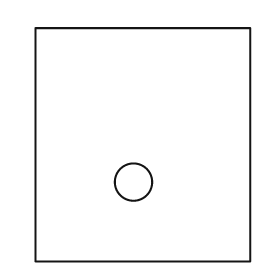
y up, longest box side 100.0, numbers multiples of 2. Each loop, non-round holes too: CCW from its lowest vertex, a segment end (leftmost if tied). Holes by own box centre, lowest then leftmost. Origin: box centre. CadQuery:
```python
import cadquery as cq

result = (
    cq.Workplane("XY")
    .moveTo(-46.0, -50.0)
    .lineTo(46.0, -50.0)
    .lineTo(46.0, 50.0)
    .lineTo(-46.0, 50.0)
    .close()
    .moveTo(-4.0, -16.0)
    .circle(8.0)
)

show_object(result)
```